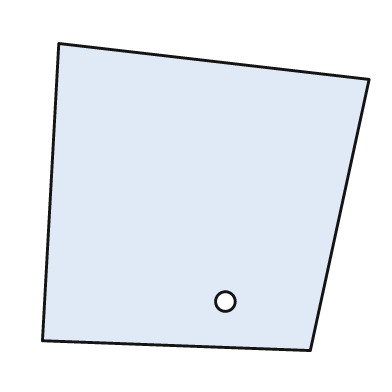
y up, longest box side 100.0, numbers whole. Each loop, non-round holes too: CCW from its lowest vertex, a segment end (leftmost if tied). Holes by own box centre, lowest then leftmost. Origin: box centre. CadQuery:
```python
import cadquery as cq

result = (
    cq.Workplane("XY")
    .moveTo(32.0, -47.0)
    .lineTo(50.0, 36.0)
    .lineTo(-45.0, 47.0)
    .lineTo(-50.0, -44.0)
    .close()
    .moveTo(6.0, -32.0)
    .circle(3.0)
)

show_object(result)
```